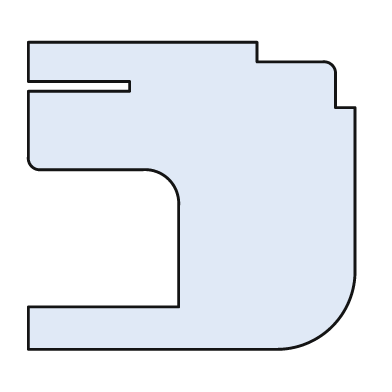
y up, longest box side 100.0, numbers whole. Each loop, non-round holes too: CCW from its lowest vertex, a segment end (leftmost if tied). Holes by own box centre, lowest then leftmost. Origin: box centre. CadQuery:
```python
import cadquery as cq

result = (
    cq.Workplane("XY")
    .moveTo(-50.0, -47.0)
    .lineTo(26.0, -47.0)
    .threePointArc((43.0, -40.0), (50.0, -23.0))
    .lineTo(50.0, 27.0)
    .lineTo(44.0, 27.0)
    .lineTo(44.0, 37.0)
    .threePointArc((43.0, 40.0), (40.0, 41.0))
    .lineTo(20.0, 41.0)
    .lineTo(20.0, 47.0)
    .lineTo(-50.0, 47.0)
    .lineTo(-50.0, 35.0)
    .lineTo(-19.0, 35.0)
    .lineTo(-19.0, 32.0)
    .lineTo(-50.0, 32.0)
    .lineTo(-50.0, 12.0)
    .threePointArc((-49.0, 9.0), (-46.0, 8.0))
    .lineTo(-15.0, 8.0)
    .threePointArc((-7.0, 5.0), (-4.0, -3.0))
    .lineTo(-4.0, -34.0)
    .lineTo(-50.0, -34.0)
    .close()
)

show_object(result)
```